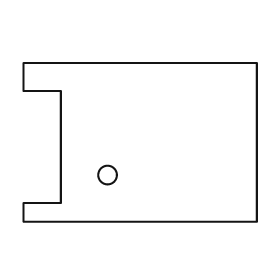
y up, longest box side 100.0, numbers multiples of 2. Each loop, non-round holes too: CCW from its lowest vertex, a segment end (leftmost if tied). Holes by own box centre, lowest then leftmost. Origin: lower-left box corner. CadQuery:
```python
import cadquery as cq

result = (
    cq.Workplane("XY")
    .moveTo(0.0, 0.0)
    .lineTo(100.0, 0.0)
    .lineTo(100.0, 68.0)
    .lineTo(0.0, 68.0)
    .lineTo(0.0, 56.0)
    .lineTo(16.0, 56.0)
    .lineTo(16.0, 8.0)
    .lineTo(0.0, 8.0)
    .close()
    .moveTo(36.0, 20.0)
    .circle(4.0)
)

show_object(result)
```